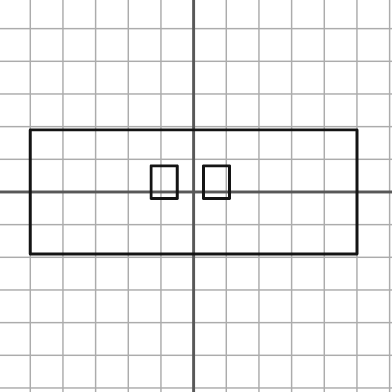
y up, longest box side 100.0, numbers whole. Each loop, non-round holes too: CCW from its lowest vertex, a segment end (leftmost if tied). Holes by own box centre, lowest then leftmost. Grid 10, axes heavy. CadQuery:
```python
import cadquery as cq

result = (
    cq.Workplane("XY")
    .moveTo(-50.0, -19.0)
    .lineTo(50.0, -19.0)
    .lineTo(50.0, 19.0)
    .lineTo(-50.0, 19.0)
    .close()
    .moveTo(-13.0, -2.0)
    .lineTo(-5.0, -2.0)
    .lineTo(-5.0, 8.0)
    .lineTo(-13.0, 8.0)
    .close()
    .moveTo(3.0, -2.0)
    .lineTo(11.0, -2.0)
    .lineTo(11.0, 8.0)
    .lineTo(3.0, 8.0)
    .close()
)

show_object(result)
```